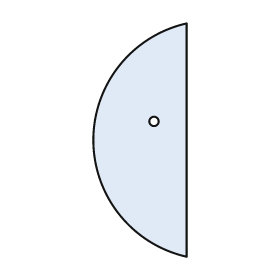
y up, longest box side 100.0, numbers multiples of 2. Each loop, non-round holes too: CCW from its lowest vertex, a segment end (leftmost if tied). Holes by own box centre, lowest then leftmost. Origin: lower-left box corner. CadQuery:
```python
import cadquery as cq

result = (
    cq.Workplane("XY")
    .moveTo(40.0, 0.0)
    .lineTo(40.0, 100.0)
    .threePointArc((0.0, 50.0), (40.0, 0.0))
    .close()
    .moveTo(26.0, 58.0)
    .circle(2.0)
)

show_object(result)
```